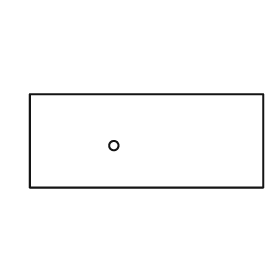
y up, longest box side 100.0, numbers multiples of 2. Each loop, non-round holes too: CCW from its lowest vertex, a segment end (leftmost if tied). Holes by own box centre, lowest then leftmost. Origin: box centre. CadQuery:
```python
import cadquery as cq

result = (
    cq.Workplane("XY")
    .moveTo(-50.0, -20.0)
    .lineTo(50.0, -20.0)
    .lineTo(50.0, 20.0)
    .lineTo(-50.0, 20.0)
    .close()
    .moveTo(-14.0, -2.0)
    .circle(2.0)
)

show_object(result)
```